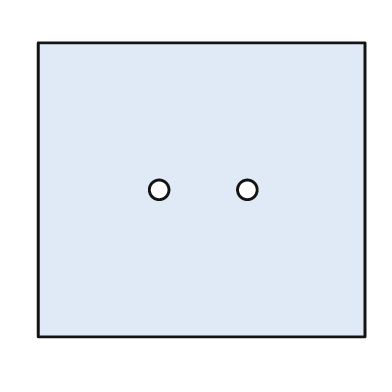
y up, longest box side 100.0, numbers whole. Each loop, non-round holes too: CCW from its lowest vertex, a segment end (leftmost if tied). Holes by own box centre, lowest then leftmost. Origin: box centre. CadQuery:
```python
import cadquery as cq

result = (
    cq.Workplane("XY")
    .moveTo(-50.0, -45.0)
    .lineTo(50.0, -45.0)
    .lineTo(50.0, 45.0)
    .lineTo(-50.0, 45.0)
    .close()
    .moveTo(-13.0, 0.0)
    .circle(3.0)
    .moveTo(14.0, 0.0)
    .circle(3.0)
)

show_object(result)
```